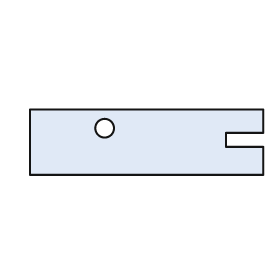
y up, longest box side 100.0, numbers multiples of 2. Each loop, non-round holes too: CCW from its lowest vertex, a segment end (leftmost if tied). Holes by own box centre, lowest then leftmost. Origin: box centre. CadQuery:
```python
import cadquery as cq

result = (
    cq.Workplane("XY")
    .moveTo(-50.0, -14.0)
    .lineTo(50.0, -14.0)
    .lineTo(50.0, -2.0)
    .lineTo(34.0, -2.0)
    .lineTo(34.0, 4.0)
    .lineTo(50.0, 4.0)
    .lineTo(50.0, 14.0)
    .lineTo(-50.0, 14.0)
    .close()
    .moveTo(-18.0, 6.0)
    .circle(4.0)
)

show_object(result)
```